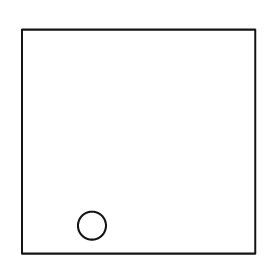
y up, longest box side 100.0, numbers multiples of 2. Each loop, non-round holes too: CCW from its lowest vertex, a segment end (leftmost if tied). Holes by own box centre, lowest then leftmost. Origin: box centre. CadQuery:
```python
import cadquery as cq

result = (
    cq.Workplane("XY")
    .moveTo(-50.0, -48.0)
    .lineTo(50.0, -48.0)
    .lineTo(50.0, 48.0)
    .lineTo(-50.0, 48.0)
    .close()
    .moveTo(-20.0, -36.0)
    .circle(6.0)
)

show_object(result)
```